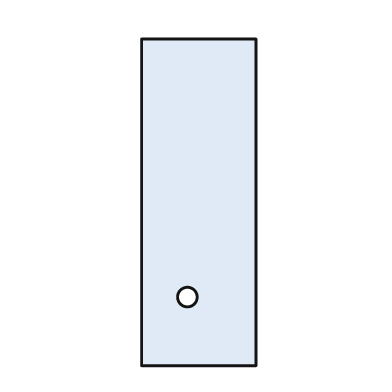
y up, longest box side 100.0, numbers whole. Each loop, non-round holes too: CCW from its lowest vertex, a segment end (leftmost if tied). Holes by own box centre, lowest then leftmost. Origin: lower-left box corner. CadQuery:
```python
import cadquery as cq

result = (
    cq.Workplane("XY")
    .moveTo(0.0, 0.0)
    .lineTo(35.0, 0.0)
    .lineTo(35.0, 100.0)
    .lineTo(0.0, 100.0)
    .close()
    .moveTo(14.0, 21.0)
    .circle(3.0)
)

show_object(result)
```